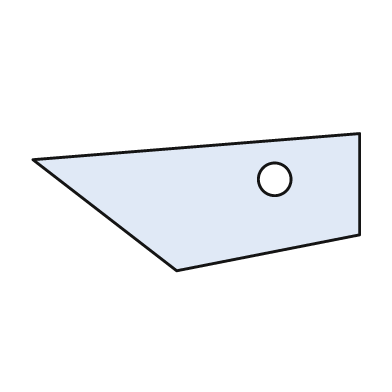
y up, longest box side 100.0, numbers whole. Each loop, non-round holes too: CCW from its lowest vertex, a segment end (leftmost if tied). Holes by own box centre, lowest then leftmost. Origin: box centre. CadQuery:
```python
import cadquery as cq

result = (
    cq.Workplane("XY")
    .moveTo(-6.0, -21.0)
    .lineTo(50.0, -10.0)
    .lineTo(50.0, 21.0)
    .lineTo(-50.0, 13.0)
    .close()
    .moveTo(24.0, 7.0)
    .circle(5.0)
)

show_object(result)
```